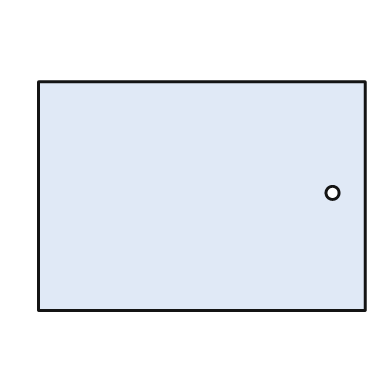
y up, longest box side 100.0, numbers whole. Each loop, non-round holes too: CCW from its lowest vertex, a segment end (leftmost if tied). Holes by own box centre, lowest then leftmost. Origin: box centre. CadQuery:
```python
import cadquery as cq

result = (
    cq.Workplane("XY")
    .moveTo(-50.0, -35.0)
    .lineTo(50.0, -35.0)
    .lineTo(50.0, 35.0)
    .lineTo(-50.0, 35.0)
    .close()
    .moveTo(40.0, 1.0)
    .circle(2.0)
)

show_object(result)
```